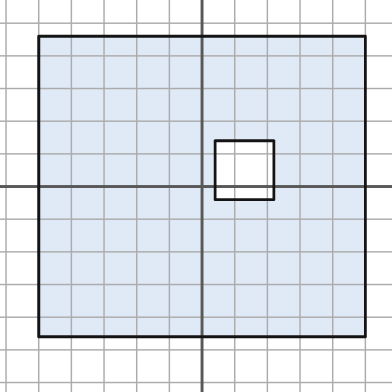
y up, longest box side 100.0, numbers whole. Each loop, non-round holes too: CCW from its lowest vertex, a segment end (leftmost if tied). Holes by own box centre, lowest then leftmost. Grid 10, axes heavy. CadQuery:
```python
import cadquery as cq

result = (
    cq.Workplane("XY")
    .moveTo(-50.0, -46.0)
    .lineTo(50.0, -46.0)
    .lineTo(50.0, 46.0)
    .lineTo(-50.0, 46.0)
    .close()
    .moveTo(4.0, -4.0)
    .lineTo(22.0, -4.0)
    .lineTo(22.0, 14.0)
    .lineTo(4.0, 14.0)
    .close()
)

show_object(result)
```